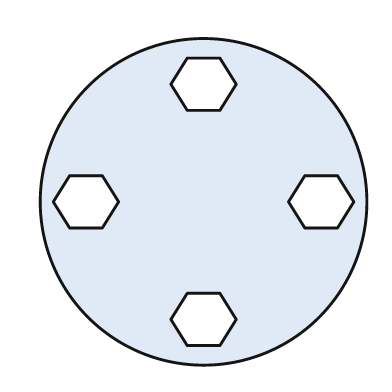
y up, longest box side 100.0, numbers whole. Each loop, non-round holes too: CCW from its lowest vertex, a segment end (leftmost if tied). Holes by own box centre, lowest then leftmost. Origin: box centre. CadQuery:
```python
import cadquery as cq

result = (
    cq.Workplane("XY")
    .moveTo(0.0, 0.0)
    .circle(50.0)
    .moveTo(-5.0, -44.0)
    .lineTo(5.0, -44.0)
    .lineTo(10.0, -36.0)
    .lineTo(5.0, -28.0)
    .lineTo(-5.0, -28.0)
    .lineTo(-10.0, -36.0)
    .close()
    .moveTo(-41.0, -8.0)
    .lineTo(-31.0, -8.0)
    .lineTo(-26.0, 0.0)
    .lineTo(-31.0, 8.0)
    .lineTo(-41.0, 8.0)
    .lineTo(-46.0, 0.0)
    .close()
    .moveTo(31.0, -8.0)
    .lineTo(41.0, -8.0)
    .lineTo(46.0, 0.0)
    .lineTo(41.0, 8.0)
    .lineTo(31.0, 8.0)
    .lineTo(26.0, 0.0)
    .close()
    .moveTo(-5.0, 28.0)
    .lineTo(5.0, 28.0)
    .lineTo(10.0, 36.0)
    .lineTo(5.0, 44.0)
    .lineTo(-5.0, 44.0)
    .lineTo(-10.0, 36.0)
    .close()
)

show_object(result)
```